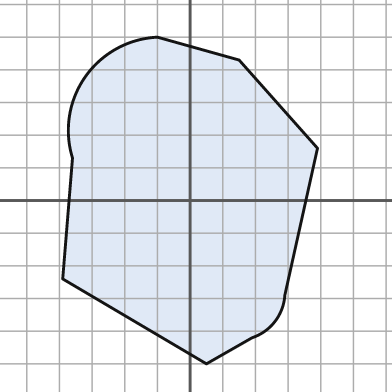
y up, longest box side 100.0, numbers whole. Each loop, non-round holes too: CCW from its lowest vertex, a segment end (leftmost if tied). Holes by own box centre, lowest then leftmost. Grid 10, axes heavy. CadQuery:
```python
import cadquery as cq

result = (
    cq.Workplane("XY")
    .moveTo(5.0, -50.0)
    .lineTo(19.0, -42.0)
    .threePointArc((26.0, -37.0), (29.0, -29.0))
    .lineTo(39.0, 16.0)
    .lineTo(15.0, 43.0)
    .lineTo(-10.0, 50.0)
    .threePointArc((-32.0, 38.0), (-36.0, 13.0))
    .lineTo(-39.0, -24.0)
    .close()
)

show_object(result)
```